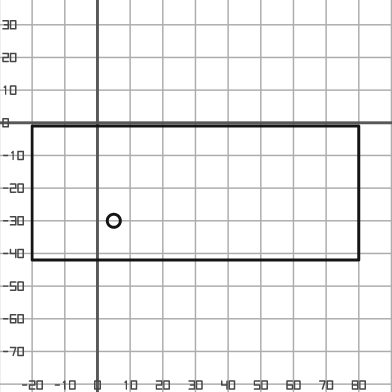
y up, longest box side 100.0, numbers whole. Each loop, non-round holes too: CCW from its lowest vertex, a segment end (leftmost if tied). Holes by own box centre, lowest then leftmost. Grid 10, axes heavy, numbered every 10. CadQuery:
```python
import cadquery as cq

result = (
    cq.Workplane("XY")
    .moveTo(-20.0, -42.0)
    .lineTo(80.0, -42.0)
    .lineTo(80.0, -1.0)
    .lineTo(-20.0, -1.0)
    .close()
    .moveTo(5.0, -30.0)
    .circle(2.0)
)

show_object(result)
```